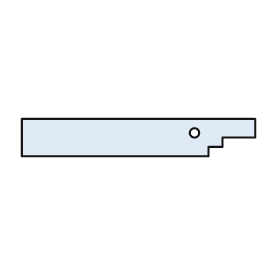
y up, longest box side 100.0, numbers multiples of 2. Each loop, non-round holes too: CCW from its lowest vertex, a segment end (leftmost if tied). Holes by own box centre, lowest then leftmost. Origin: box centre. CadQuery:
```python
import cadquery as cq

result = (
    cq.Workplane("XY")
    .moveTo(-50.0, -8.0)
    .lineTo(30.0, -8.0)
    .lineTo(30.0, -4.0)
    .lineTo(36.0, -4.0)
    .lineTo(36.0, 0.0)
    .lineTo(50.0, 0.0)
    .lineTo(50.0, 8.0)
    .lineTo(-50.0, 8.0)
    .close()
    .moveTo(24.0, 2.0)
    .circle(2.0)
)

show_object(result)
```